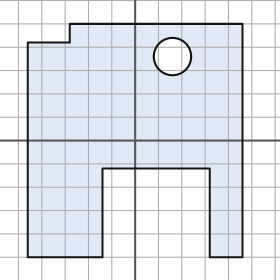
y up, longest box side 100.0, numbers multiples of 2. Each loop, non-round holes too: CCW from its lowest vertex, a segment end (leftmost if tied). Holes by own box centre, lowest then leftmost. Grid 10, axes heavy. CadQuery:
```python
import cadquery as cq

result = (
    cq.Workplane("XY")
    .moveTo(-46.0, -50.0)
    .lineTo(-14.0, -50.0)
    .lineTo(-14.0, -12.0)
    .lineTo(32.0, -12.0)
    .lineTo(32.0, -50.0)
    .lineTo(46.0, -50.0)
    .lineTo(46.0, 50.0)
    .lineTo(-28.0, 50.0)
    .lineTo(-28.0, 42.0)
    .lineTo(-46.0, 42.0)
    .close()
    .moveTo(16.0, 36.0)
    .circle(8.0)
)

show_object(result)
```